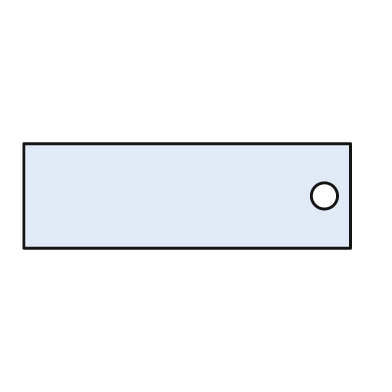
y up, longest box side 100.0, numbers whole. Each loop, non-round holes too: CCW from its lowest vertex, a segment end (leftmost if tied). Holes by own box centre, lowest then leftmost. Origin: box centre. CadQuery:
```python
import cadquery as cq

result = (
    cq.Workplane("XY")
    .moveTo(-50.0, -16.0)
    .lineTo(50.0, -16.0)
    .lineTo(50.0, 16.0)
    .lineTo(-50.0, 16.0)
    .close()
    .moveTo(42.0, 0.0)
    .circle(4.0)
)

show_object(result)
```